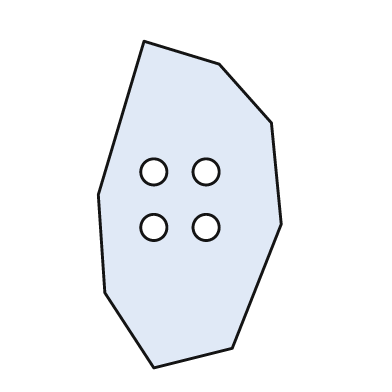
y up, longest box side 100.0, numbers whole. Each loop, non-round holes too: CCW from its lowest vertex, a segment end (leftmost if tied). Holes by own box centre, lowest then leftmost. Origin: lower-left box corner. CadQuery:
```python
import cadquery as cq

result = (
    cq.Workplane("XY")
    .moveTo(17.0, 0.0)
    .lineTo(41.0, 6.0)
    .lineTo(56.0, 44.0)
    .lineTo(53.0, 75.0)
    .lineTo(37.0, 93.0)
    .lineTo(14.0, 100.0)
    .lineTo(0.0, 53.0)
    .lineTo(2.0, 23.0)
    .close()
    .moveTo(17.0, 43.0)
    .circle(4.0)
    .moveTo(33.0, 43.0)
    .circle(4.0)
    .moveTo(17.0, 60.0)
    .circle(4.0)
    .moveTo(33.0, 60.0)
    .circle(4.0)
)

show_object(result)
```